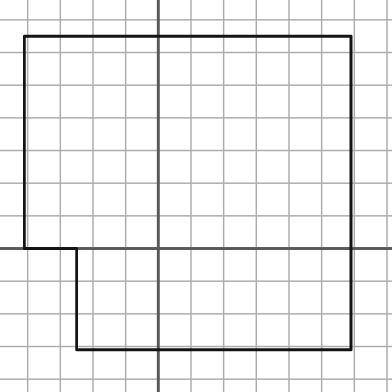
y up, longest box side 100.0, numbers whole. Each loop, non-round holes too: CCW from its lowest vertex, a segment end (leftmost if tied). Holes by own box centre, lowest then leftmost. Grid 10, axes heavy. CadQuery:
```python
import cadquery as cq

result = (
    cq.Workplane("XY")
    .moveTo(-25.0, -31.0)
    .lineTo(59.0, -31.0)
    .lineTo(59.0, 65.0)
    .lineTo(-41.0, 65.0)
    .lineTo(-41.0, 0.0)
    .lineTo(-25.0, 0.0)
    .close()
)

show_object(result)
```